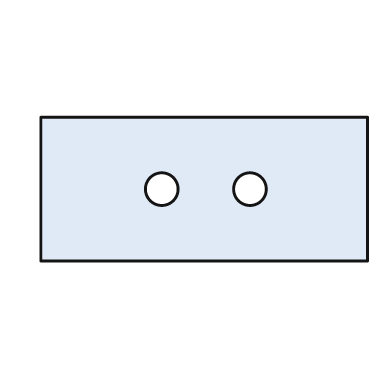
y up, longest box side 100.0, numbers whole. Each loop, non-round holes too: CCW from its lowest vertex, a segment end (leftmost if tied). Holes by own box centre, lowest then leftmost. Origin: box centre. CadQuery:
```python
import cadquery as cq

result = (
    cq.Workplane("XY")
    .moveTo(-50.0, -22.0)
    .lineTo(50.0, -22.0)
    .lineTo(50.0, 22.0)
    .lineTo(-50.0, 22.0)
    .close()
    .moveTo(-13.0, 0.0)
    .circle(5.0)
    .moveTo(14.0, 0.0)
    .circle(5.0)
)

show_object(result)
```